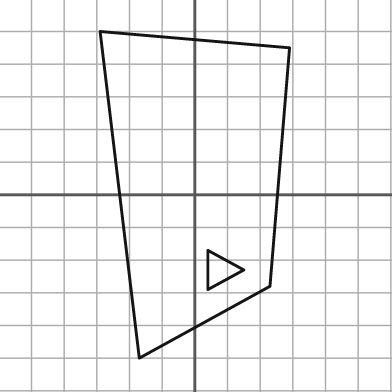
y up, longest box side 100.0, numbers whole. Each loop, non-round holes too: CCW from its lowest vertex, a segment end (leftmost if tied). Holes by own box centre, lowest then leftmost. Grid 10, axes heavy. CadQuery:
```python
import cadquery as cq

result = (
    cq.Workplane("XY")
    .moveTo(-17.0, -50.0)
    .lineTo(23.0, -28.0)
    .lineTo(29.0, 45.0)
    .lineTo(-29.0, 50.0)
    .close()
    .moveTo(4.0, -29.0)
    .lineTo(15.0, -23.0)
    .lineTo(4.0, -17.0)
    .close()
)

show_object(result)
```